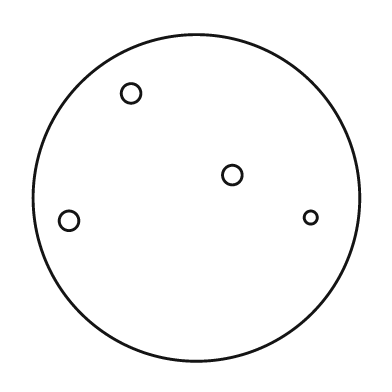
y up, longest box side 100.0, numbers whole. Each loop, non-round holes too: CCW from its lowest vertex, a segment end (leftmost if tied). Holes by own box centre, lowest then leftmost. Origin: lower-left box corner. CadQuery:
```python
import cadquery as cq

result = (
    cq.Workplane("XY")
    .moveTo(50.0, 50.0)
    .circle(50.0)
    .moveTo(11.0, 43.0)
    .circle(3.0)
    .moveTo(85.0, 44.0)
    .circle(2.0)
    .moveTo(61.0, 57.0)
    .circle(3.0)
    .moveTo(30.0, 82.0)
    .circle(3.0)
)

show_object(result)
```